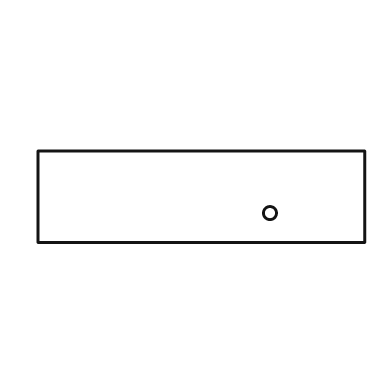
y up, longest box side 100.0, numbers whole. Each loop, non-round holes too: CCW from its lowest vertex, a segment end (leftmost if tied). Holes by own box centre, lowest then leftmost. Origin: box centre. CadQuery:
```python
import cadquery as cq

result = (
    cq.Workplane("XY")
    .moveTo(-50.0, -14.0)
    .lineTo(50.0, -14.0)
    .lineTo(50.0, 14.0)
    .lineTo(-50.0, 14.0)
    .close()
    .moveTo(21.0, -5.0)
    .circle(2.0)
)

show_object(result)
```